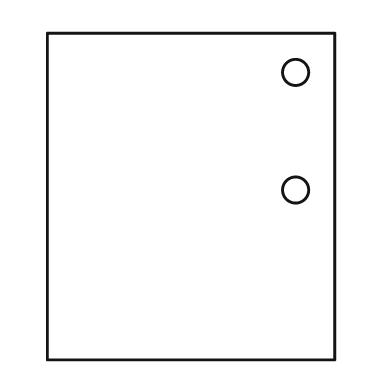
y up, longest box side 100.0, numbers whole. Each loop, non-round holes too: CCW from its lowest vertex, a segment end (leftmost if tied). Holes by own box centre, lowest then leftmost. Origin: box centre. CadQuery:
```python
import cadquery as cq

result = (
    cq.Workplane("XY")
    .moveTo(-44.0, -50.0)
    .lineTo(44.0, -50.0)
    .lineTo(44.0, 50.0)
    .lineTo(-44.0, 50.0)
    .close()
    .moveTo(32.0, 2.0)
    .circle(4.0)
    .moveTo(32.0, 38.0)
    .circle(4.0)
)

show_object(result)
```